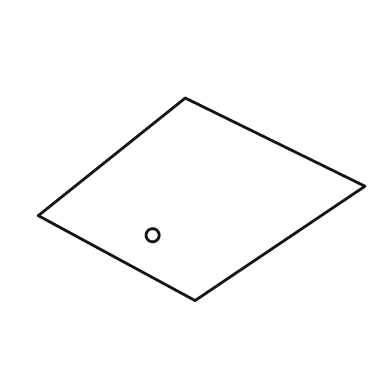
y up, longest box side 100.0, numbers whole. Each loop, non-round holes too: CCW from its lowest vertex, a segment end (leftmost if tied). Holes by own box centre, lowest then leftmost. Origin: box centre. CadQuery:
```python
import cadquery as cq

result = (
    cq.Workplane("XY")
    .moveTo(-2.0, -31.0)
    .lineTo(50.0, 4.0)
    .lineTo(-5.0, 31.0)
    .lineTo(-50.0, -5.0)
    .close()
    .moveTo(-15.0, -11.0)
    .circle(2.0)
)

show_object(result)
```